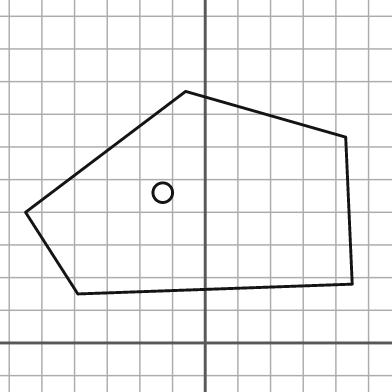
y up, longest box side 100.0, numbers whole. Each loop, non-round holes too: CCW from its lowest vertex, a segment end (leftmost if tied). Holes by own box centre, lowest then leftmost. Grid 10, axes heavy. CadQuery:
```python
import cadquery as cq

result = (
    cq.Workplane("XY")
    .moveTo(-39.0, 15.0)
    .lineTo(45.0, 18.0)
    .lineTo(43.0, 63.0)
    .lineTo(-6.0, 77.0)
    .lineTo(-55.0, 40.0)
    .close()
    .moveTo(-13.0, 46.0)
    .circle(3.0)
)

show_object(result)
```